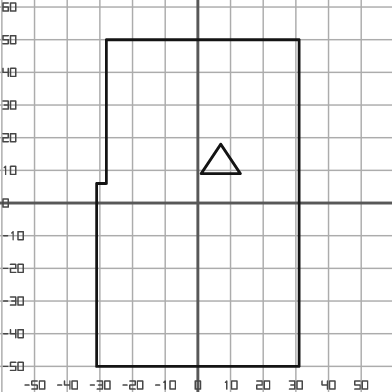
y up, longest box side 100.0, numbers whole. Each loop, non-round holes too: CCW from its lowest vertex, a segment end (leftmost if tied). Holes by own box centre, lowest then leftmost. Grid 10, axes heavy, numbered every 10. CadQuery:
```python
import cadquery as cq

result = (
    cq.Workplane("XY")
    .moveTo(-31.0, -50.0)
    .lineTo(31.0, -50.0)
    .lineTo(31.0, 50.0)
    .lineTo(-28.0, 50.0)
    .lineTo(-28.0, 6.0)
    .lineTo(-31.0, 6.0)
    .close()
    .moveTo(1.0, 9.0)
    .lineTo(13.0, 9.0)
    .lineTo(7.0, 18.0)
    .close()
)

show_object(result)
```